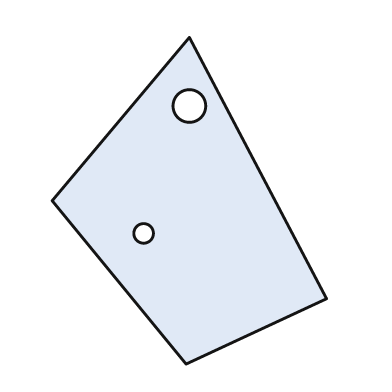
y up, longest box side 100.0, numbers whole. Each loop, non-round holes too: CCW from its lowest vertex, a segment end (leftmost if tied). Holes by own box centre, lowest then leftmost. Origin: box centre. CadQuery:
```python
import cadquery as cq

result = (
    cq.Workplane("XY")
    .moveTo(-1.0, -50.0)
    .lineTo(42.0, -30.0)
    .lineTo(0.0, 50.0)
    .lineTo(-42.0, 0.0)
    .close()
    .moveTo(-14.0, -10.0)
    .circle(3.0)
    .moveTo(0.0, 29.0)
    .circle(5.0)
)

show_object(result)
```